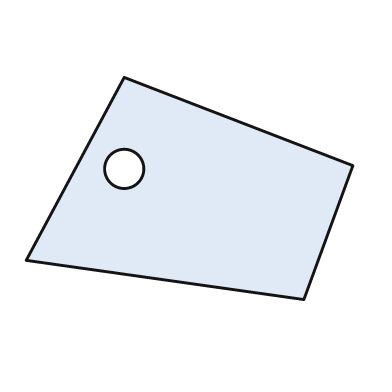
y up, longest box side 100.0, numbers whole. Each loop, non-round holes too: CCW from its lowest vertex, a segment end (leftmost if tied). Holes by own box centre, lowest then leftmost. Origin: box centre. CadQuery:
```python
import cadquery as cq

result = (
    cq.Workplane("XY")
    .moveTo(35.0, -34.0)
    .lineTo(50.0, 7.0)
    .lineTo(-20.0, 34.0)
    .lineTo(-50.0, -22.0)
    .close()
    .moveTo(-20.0, 6.0)
    .circle(6.0)
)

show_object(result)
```